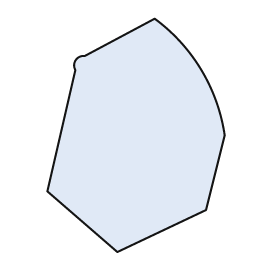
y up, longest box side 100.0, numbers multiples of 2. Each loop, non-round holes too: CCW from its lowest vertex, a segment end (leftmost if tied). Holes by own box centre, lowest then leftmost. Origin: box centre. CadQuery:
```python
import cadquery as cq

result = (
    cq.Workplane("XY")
    .moveTo(-8.0, -50.0)
    .lineTo(30.0, -32.0)
    .lineTo(38.0, 0.0)
    .threePointArc((28.0, 28.0), (8.0, 50.0))
    .lineTo(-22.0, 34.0)
    .threePointArc((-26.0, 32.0), (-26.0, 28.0))
    .lineTo(-38.0, -24.0)
    .close()
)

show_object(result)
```